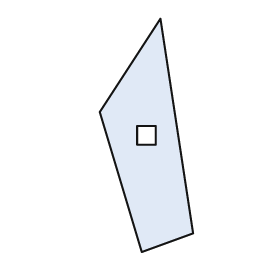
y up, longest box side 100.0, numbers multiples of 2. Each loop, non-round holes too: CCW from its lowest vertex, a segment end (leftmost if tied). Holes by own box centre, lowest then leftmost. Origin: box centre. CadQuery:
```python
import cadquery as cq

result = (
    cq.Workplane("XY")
    .moveTo(-2.0, -50.0)
    .lineTo(20.0, -42.0)
    .lineTo(6.0, 50.0)
    .lineTo(-20.0, 10.0)
    .close()
    .moveTo(-4.0, -4.0)
    .lineTo(4.0, -4.0)
    .lineTo(4.0, 4.0)
    .lineTo(-4.0, 4.0)
    .close()
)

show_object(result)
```